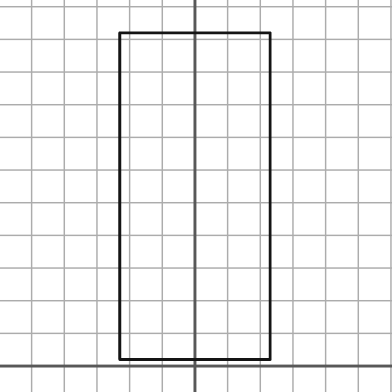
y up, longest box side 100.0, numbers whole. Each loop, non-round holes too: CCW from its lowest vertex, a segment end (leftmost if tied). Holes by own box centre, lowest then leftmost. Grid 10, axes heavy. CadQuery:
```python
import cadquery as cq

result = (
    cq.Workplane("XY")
    .moveTo(-23.0, 2.0)
    .lineTo(23.0, 2.0)
    .lineTo(23.0, 102.0)
    .lineTo(-23.0, 102.0)
    .close()
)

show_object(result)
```